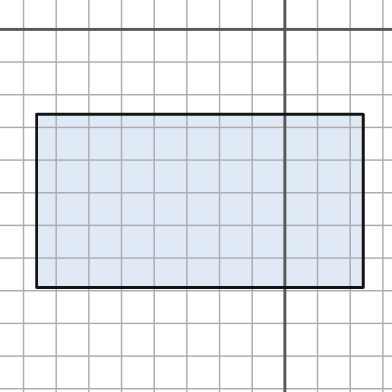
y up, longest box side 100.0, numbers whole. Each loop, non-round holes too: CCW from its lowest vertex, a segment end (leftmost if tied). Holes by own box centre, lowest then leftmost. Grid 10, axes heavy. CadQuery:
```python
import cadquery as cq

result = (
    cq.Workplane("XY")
    .moveTo(-76.0, -79.0)
    .lineTo(24.0, -79.0)
    .lineTo(24.0, -26.0)
    .lineTo(-76.0, -26.0)
    .close()
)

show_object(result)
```